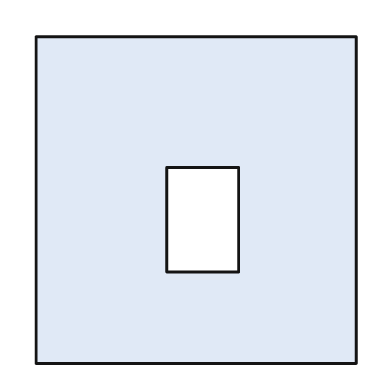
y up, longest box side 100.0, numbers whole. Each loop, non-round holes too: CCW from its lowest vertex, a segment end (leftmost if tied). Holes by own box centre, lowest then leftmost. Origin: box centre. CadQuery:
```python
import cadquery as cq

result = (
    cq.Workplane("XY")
    .moveTo(-49.0, -50.0)
    .lineTo(49.0, -50.0)
    .lineTo(49.0, 50.0)
    .lineTo(-49.0, 50.0)
    .close()
    .moveTo(-9.0, -22.0)
    .lineTo(13.0, -22.0)
    .lineTo(13.0, 10.0)
    .lineTo(-9.0, 10.0)
    .close()
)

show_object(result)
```